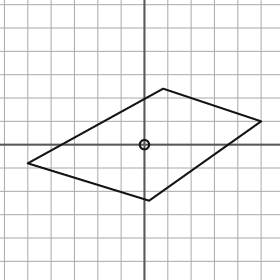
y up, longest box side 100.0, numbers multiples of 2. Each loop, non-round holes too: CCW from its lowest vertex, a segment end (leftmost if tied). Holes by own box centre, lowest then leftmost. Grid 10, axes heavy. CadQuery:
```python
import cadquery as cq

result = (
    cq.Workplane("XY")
    .moveTo(2.0, -24.0)
    .lineTo(50.0, 10.0)
    .lineTo(8.0, 24.0)
    .lineTo(-50.0, -8.0)
    .close()
    .moveTo(0.0, 0.0)
    .circle(2.0)
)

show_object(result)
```